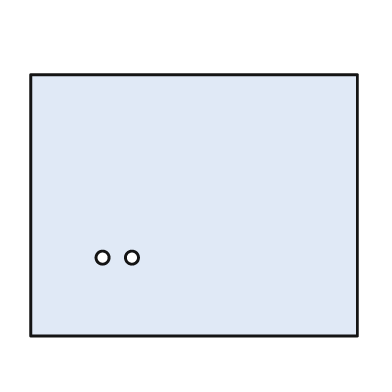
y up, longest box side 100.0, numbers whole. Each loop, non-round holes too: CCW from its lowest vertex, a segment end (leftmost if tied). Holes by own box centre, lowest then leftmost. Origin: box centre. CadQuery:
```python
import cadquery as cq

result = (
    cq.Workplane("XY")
    .moveTo(-50.0, -40.0)
    .lineTo(50.0, -40.0)
    .lineTo(50.0, 40.0)
    .lineTo(-50.0, 40.0)
    .close()
    .moveTo(-28.0, -16.0)
    .circle(2.0)
    .moveTo(-19.0, -16.0)
    .circle(2.0)
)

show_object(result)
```